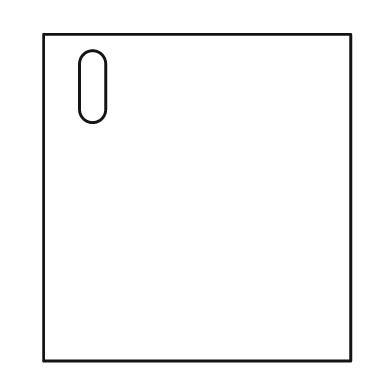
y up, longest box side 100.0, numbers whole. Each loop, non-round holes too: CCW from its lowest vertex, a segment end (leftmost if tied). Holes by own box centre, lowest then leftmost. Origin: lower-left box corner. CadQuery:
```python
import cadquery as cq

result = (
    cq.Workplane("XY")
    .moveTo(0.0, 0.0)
    .lineTo(94.0, 0.0)
    .lineTo(94.0, 100.0)
    .lineTo(0.0, 100.0)
    .close()
    .moveTo(11.0, 77.0)
    .threePointArc((15.0, 73.0), (19.0, 77.0))
    .lineTo(19.0, 91.0)
    .threePointArc((15.0, 95.0), (11.0, 91.0))
    .close()
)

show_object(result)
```